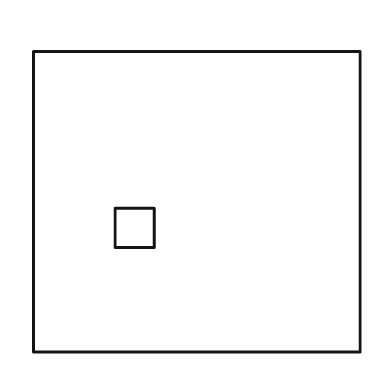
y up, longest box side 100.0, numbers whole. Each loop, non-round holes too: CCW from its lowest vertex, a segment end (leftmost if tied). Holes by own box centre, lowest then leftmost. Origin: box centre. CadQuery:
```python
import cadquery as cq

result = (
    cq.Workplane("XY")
    .moveTo(-50.0, -46.0)
    .lineTo(50.0, -46.0)
    .lineTo(50.0, 46.0)
    .lineTo(-50.0, 46.0)
    .close()
    .moveTo(-25.0, -14.0)
    .lineTo(-13.0, -14.0)
    .lineTo(-13.0, -2.0)
    .lineTo(-25.0, -2.0)
    .close()
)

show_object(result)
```